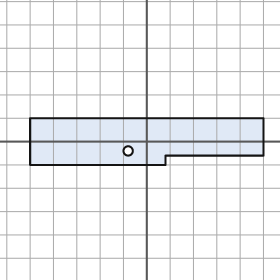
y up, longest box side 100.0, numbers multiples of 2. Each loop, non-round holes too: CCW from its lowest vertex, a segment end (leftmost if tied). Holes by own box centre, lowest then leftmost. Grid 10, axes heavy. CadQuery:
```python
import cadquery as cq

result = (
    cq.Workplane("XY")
    .moveTo(-50.0, -10.0)
    .lineTo(8.0, -10.0)
    .lineTo(8.0, -6.0)
    .lineTo(50.0, -6.0)
    .lineTo(50.0, 10.0)
    .lineTo(-50.0, 10.0)
    .close()
    .moveTo(-8.0, -4.0)
    .circle(2.0)
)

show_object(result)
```